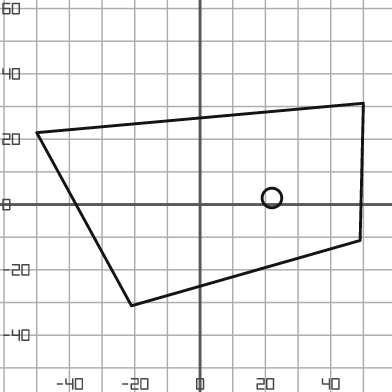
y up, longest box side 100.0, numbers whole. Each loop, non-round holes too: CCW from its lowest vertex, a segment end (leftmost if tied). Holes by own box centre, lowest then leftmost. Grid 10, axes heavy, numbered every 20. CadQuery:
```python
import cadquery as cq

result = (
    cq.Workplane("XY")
    .moveTo(-21.0, -31.0)
    .lineTo(49.0, -11.0)
    .lineTo(50.0, 31.0)
    .lineTo(-50.0, 22.0)
    .close()
    .moveTo(22.0, 2.0)
    .circle(3.0)
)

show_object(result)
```